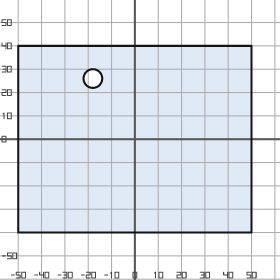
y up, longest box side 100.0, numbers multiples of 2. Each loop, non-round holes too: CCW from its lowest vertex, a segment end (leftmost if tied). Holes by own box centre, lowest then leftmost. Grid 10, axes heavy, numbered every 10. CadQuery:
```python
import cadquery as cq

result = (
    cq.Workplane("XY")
    .moveTo(-50.0, -40.0)
    .lineTo(50.0, -40.0)
    .lineTo(50.0, 40.0)
    .lineTo(-50.0, 40.0)
    .close()
    .moveTo(-18.0, 26.0)
    .circle(4.0)
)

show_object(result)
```